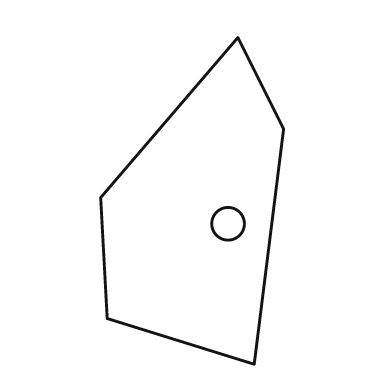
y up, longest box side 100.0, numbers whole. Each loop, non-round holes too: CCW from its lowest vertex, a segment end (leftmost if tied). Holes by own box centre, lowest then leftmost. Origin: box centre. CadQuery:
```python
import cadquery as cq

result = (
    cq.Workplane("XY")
    .moveTo(19.0, -50.0)
    .lineTo(28.0, 22.0)
    .lineTo(14.0, 50.0)
    .lineTo(-28.0, 1.0)
    .lineTo(-26.0, -36.0)
    .close()
    .moveTo(11.0, -7.0)
    .circle(5.0)
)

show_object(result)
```